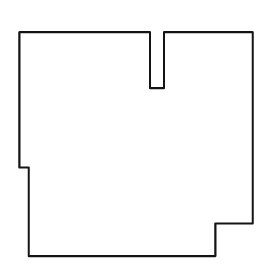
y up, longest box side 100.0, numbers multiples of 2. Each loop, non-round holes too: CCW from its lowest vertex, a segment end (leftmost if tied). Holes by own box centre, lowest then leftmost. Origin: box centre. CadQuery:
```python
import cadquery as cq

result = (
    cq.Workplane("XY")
    .moveTo(-46.0, -48.0)
    .lineTo(34.0, -48.0)
    .lineTo(34.0, -34.0)
    .lineTo(50.0, -34.0)
    .lineTo(50.0, 48.0)
    .lineTo(12.0, 48.0)
    .lineTo(12.0, 24.0)
    .lineTo(6.0, 24.0)
    .lineTo(6.0, 48.0)
    .lineTo(-50.0, 48.0)
    .lineTo(-50.0, -10.0)
    .lineTo(-46.0, -10.0)
    .close()
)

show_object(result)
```